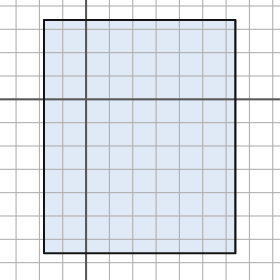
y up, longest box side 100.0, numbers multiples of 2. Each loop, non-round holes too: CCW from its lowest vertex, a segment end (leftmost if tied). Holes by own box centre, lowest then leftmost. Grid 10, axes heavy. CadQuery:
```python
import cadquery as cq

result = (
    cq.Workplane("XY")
    .moveTo(-18.0, -66.0)
    .lineTo(64.0, -66.0)
    .lineTo(64.0, 34.0)
    .lineTo(-18.0, 34.0)
    .close()
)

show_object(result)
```